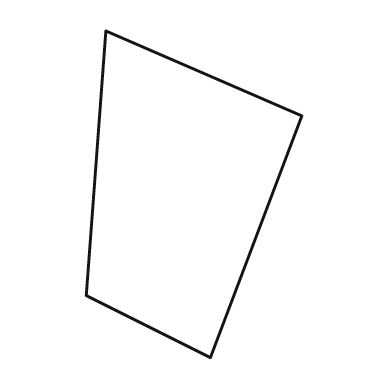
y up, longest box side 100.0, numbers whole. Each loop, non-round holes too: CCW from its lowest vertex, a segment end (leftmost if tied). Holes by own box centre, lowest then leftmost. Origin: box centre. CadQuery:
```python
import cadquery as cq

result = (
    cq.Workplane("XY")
    .moveTo(5.0, -50.0)
    .lineTo(33.0, 24.0)
    .lineTo(-27.0, 50.0)
    .lineTo(-33.0, -31.0)
    .close()
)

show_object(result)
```